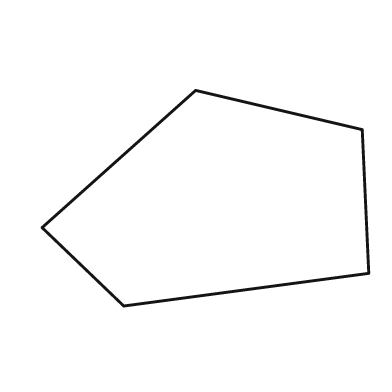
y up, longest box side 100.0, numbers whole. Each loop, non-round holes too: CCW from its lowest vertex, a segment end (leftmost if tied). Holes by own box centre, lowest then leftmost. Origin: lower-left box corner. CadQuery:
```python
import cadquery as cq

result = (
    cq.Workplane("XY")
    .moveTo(25.0, 0.0)
    .lineTo(100.0, 10.0)
    .lineTo(98.0, 54.0)
    .lineTo(47.0, 66.0)
    .lineTo(0.0, 24.0)
    .close()
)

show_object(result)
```